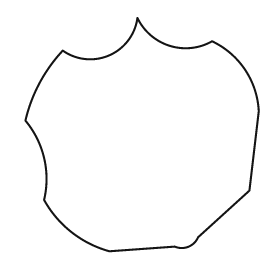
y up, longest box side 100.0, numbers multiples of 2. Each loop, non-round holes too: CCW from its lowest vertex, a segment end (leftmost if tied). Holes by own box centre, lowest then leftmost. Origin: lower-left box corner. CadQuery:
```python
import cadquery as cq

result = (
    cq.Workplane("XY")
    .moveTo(36.0, 0.0)
    .lineTo(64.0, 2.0)
    .threePointArc((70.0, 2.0), (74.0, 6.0))
    .lineTo(96.0, 26.0)
    .lineTo(100.0, 60.0)
    .threePointArc((94.0, 78.0), (80.0, 90.0))
    .threePointArc((62.0, 88.0), (48.0, 100.0))
    .threePointArc((36.0, 84.0), (16.0, 86.0))
    .threePointArc((6.0, 72.0), (0.0, 56.0))
    .threePointArc((8.0, 40.0), (8.0, 22.0))
    .threePointArc((20.0, 8.0), (36.0, 0.0))
    .close()
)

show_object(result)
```